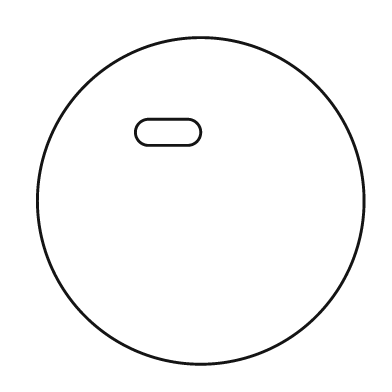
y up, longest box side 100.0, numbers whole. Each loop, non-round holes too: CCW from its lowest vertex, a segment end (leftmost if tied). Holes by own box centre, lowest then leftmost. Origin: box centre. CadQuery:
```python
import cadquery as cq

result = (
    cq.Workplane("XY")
    .moveTo(0.0, 0.0)
    .circle(50.0)
    .moveTo(-16.0, 17.0)
    .lineTo(-4.0, 17.0)
    .threePointArc((0.0, 21.0), (-4.0, 25.0))
    .lineTo(-16.0, 25.0)
    .threePointArc((-20.0, 21.0), (-16.0, 17.0))
    .close()
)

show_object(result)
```